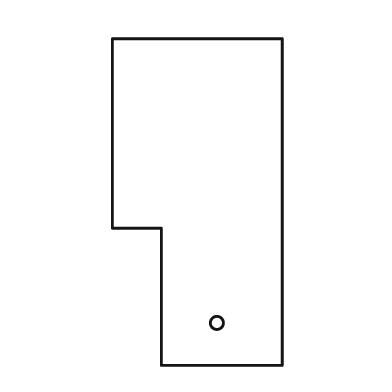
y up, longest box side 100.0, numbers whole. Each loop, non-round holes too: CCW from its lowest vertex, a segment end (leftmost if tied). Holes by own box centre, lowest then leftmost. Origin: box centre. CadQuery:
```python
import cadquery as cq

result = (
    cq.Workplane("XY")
    .moveTo(-11.0, -50.0)
    .lineTo(26.0, -50.0)
    .lineTo(26.0, 50.0)
    .lineTo(-26.0, 50.0)
    .lineTo(-26.0, -8.0)
    .lineTo(-11.0, -8.0)
    .close()
    .moveTo(6.0, -37.0)
    .circle(2.0)
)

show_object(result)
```